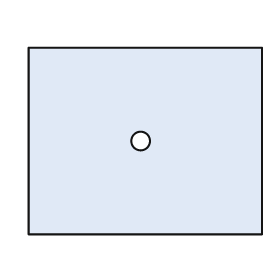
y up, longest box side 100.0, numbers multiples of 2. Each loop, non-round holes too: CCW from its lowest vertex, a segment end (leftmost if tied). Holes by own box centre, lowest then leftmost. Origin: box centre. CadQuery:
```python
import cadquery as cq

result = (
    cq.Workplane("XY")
    .moveTo(-50.0, -40.0)
    .lineTo(50.0, -40.0)
    .lineTo(50.0, 40.0)
    .lineTo(-50.0, 40.0)
    .close()
    .moveTo(-2.0, 0.0)
    .circle(4.0)
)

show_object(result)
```